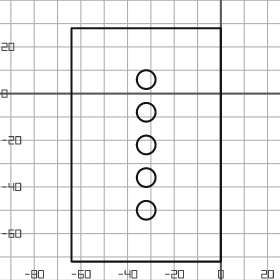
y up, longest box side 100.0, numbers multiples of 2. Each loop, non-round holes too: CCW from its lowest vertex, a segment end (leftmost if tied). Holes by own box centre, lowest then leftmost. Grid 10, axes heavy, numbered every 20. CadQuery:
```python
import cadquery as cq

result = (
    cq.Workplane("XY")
    .moveTo(-64.0, -72.0)
    .lineTo(0.0, -72.0)
    .lineTo(0.0, 28.0)
    .lineTo(-64.0, 28.0)
    .close()
    .moveTo(-32.0, -50.0)
    .circle(4.0)
    .moveTo(-32.0, -36.0)
    .circle(4.0)
    .moveTo(-32.0, -22.0)
    .circle(4.0)
    .moveTo(-32.0, -8.0)
    .circle(4.0)
    .moveTo(-32.0, 6.0)
    .circle(4.0)
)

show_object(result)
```